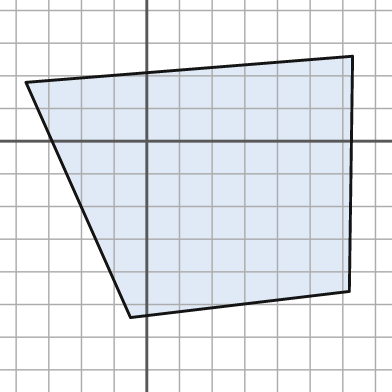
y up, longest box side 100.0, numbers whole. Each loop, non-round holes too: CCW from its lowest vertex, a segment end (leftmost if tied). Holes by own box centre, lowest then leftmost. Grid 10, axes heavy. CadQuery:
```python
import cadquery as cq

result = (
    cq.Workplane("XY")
    .moveTo(-5.0, -54.0)
    .lineTo(62.0, -46.0)
    .lineTo(63.0, 26.0)
    .lineTo(-37.0, 18.0)
    .close()
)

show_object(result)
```